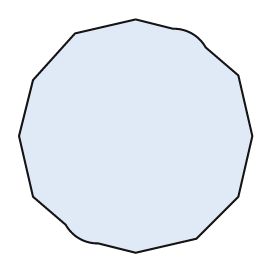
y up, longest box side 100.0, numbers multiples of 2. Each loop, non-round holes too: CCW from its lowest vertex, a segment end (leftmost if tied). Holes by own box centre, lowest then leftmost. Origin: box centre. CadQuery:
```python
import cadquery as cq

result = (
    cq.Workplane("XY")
    .moveTo(0.0, -50.0)
    .lineTo(26.0, -44.0)
    .lineTo(44.0, -26.0)
    .lineTo(50.0, 0.0)
    .lineTo(44.0, 26.0)
    .lineTo(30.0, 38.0)
    .threePointArc((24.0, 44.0), (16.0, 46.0))
    .lineTo(0.0, 50.0)
    .lineTo(-26.0, 44.0)
    .lineTo(-44.0, 24.0)
    .lineTo(-50.0, 0.0)
    .lineTo(-44.0, -26.0)
    .lineTo(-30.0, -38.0)
    .threePointArc((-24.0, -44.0), (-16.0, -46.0))
    .close()
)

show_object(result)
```